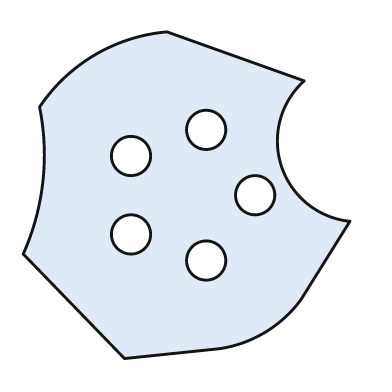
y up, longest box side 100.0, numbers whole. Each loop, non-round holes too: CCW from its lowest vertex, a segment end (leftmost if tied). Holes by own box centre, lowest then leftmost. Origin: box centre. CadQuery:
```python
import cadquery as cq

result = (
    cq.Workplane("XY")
    .moveTo(-19.0, -50.0)
    .lineTo(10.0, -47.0)
    .threePointArc((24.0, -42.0), (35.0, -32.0))
    .lineTo(50.0, -8.0)
    .threePointArc((29.0, 9.0), (36.0, 35.0))
    .lineTo(-6.0, 50.0)
    .threePointArc((-28.0, 43.0), (-45.0, 27.0))
    .threePointArc((-44.0, 4.0), (-50.0, -18.0))
    .close()
    .moveTo(6.0, -20.0)
    .circle(6.0)
    .moveTo(-17.0, -12.0)
    .circle(6.0)
    .moveTo(21.0, 0.0)
    .circle(6.0)
    .moveTo(-17.0, 12.0)
    .circle(6.0)
    .moveTo(6.0, 20.0)
    .circle(6.0)
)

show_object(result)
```